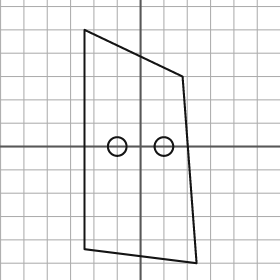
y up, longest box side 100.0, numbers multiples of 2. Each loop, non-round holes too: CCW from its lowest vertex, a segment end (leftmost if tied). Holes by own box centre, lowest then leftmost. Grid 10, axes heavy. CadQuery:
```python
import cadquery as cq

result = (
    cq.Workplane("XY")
    .moveTo(24.0, -50.0)
    .lineTo(18.0, 30.0)
    .lineTo(-24.0, 50.0)
    .lineTo(-24.0, -44.0)
    .close()
    .moveTo(-10.0, 0.0)
    .circle(4.0)
    .moveTo(10.0, 0.0)
    .circle(4.0)
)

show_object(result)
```